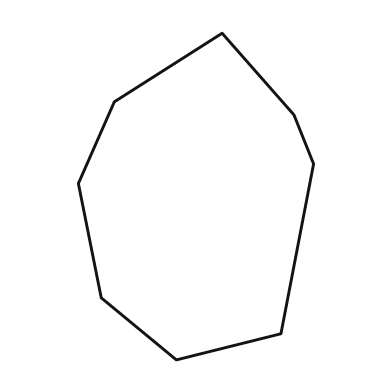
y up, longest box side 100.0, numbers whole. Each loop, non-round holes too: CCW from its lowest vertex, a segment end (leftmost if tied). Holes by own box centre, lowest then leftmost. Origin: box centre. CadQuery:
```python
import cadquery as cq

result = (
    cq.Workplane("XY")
    .moveTo(-6.0, -50.0)
    .lineTo(26.0, -42.0)
    .lineTo(36.0, 10.0)
    .lineTo(30.0, 25.0)
    .lineTo(8.0, 50.0)
    .lineTo(-25.0, 29.0)
    .lineTo(-36.0, 4.0)
    .lineTo(-29.0, -31.0)
    .close()
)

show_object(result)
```